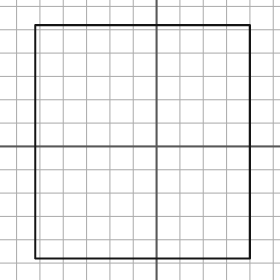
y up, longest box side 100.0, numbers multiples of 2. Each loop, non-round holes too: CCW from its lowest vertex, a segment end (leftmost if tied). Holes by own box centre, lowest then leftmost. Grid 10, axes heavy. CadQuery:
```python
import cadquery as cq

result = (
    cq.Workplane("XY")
    .moveTo(-52.0, -48.0)
    .lineTo(40.0, -48.0)
    .lineTo(40.0, 52.0)
    .lineTo(-52.0, 52.0)
    .close()
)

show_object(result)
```